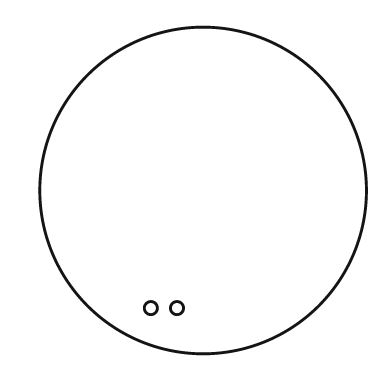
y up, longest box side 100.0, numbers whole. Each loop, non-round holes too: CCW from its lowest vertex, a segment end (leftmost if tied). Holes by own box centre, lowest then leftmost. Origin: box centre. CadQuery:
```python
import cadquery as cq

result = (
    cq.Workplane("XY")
    .moveTo(0.0, 0.0)
    .circle(50.0)
    .moveTo(-16.0, -36.0)
    .circle(2.0)
    .moveTo(-8.0, -36.0)
    .circle(2.0)
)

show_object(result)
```